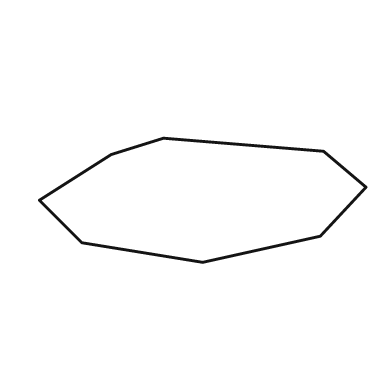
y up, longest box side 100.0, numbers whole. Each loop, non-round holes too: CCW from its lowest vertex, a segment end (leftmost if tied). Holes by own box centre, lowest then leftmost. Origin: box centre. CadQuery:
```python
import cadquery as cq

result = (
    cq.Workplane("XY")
    .moveTo(0.0, -19.0)
    .lineTo(36.0, -11.0)
    .lineTo(50.0, 4.0)
    .lineTo(37.0, 15.0)
    .lineTo(-12.0, 19.0)
    .lineTo(-28.0, 14.0)
    .lineTo(-50.0, 0.0)
    .lineTo(-37.0, -13.0)
    .close()
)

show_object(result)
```